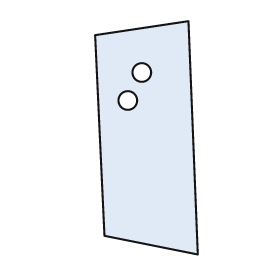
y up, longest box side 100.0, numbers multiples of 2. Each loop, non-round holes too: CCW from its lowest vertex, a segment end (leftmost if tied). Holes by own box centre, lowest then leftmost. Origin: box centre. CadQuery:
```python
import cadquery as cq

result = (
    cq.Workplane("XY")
    .moveTo(22.0, -50.0)
    .lineTo(18.0, 50.0)
    .lineTo(-22.0, 44.0)
    .lineTo(-18.0, -42.0)
    .close()
    .moveTo(-8.0, 16.0)
    .circle(4.0)
    .moveTo(-2.0, 28.0)
    .circle(4.0)
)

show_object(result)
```